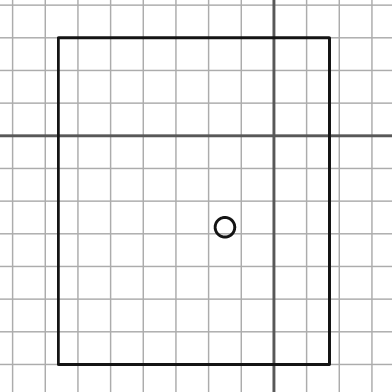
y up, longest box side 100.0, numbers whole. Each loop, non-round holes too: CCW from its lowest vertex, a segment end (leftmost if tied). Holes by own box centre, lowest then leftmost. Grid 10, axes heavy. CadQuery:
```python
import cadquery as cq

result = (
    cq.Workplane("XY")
    .moveTo(-66.0, -70.0)
    .lineTo(17.0, -70.0)
    .lineTo(17.0, 30.0)
    .lineTo(-66.0, 30.0)
    .close()
    .moveTo(-15.0, -28.0)
    .circle(3.0)
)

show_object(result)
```